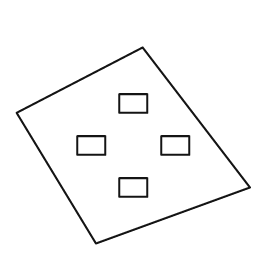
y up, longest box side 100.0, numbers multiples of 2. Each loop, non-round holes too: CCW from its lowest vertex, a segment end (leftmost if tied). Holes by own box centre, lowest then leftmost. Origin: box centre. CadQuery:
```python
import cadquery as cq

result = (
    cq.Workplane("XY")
    .moveTo(-16.0, -42.0)
    .lineTo(50.0, -18.0)
    .lineTo(4.0, 42.0)
    .lineTo(-50.0, 14.0)
    .close()
    .moveTo(-6.0, -22.0)
    .lineTo(6.0, -22.0)
    .lineTo(6.0, -14.0)
    .lineTo(-6.0, -14.0)
    .close()
    .moveTo(-24.0, -4.0)
    .lineTo(-12.0, -4.0)
    .lineTo(-12.0, 4.0)
    .lineTo(-24.0, 4.0)
    .close()
    .moveTo(12.0, -4.0)
    .lineTo(24.0, -4.0)
    .lineTo(24.0, 4.0)
    .lineTo(12.0, 4.0)
    .close()
    .moveTo(-6.0, 14.0)
    .lineTo(6.0, 14.0)
    .lineTo(6.0, 22.0)
    .lineTo(-6.0, 22.0)
    .close()
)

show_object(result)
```